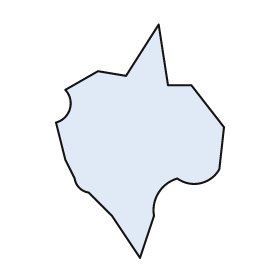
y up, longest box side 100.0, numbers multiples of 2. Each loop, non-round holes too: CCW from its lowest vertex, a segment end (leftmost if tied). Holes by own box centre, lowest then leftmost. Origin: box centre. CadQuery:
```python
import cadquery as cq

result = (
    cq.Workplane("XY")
    .moveTo(0.0, -50.0)
    .lineTo(6.0, -32.0)
    .threePointArc((8.0, -22.0), (16.0, -16.0))
    .threePointArc((26.0, -18.0), (34.0, -12.0))
    .lineTo(36.0, 6.0)
    .lineTo(22.0, 24.0)
    .lineTo(12.0, 24.0)
    .lineTo(8.0, 50.0)
    .lineTo(-6.0, 28.0)
    .lineTo(-18.0, 30.0)
    .lineTo(-32.0, 22.0)
    .threePointArc((-30.0, 14.0), (-36.0, 8.0))
    .lineTo(-32.0, -8.0)
    .lineTo(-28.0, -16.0)
    .threePointArc((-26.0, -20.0), (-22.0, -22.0))
    .lineTo(-12.0, -32.0)
    .close()
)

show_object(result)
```